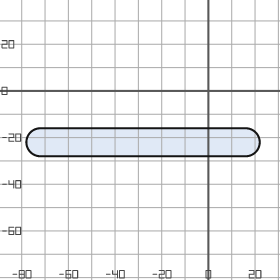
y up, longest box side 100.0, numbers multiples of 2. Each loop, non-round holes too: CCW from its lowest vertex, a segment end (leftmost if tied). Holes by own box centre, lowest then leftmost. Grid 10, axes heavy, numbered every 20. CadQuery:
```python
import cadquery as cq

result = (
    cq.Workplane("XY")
    .moveTo(-72.0, -28.0)
    .lineTo(16.0, -28.0)
    .threePointArc((22.0, -22.0), (16.0, -16.0))
    .lineTo(-72.0, -16.0)
    .threePointArc((-78.0, -22.0), (-72.0, -28.0))
    .close()
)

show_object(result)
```